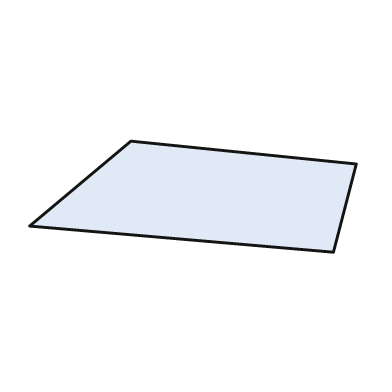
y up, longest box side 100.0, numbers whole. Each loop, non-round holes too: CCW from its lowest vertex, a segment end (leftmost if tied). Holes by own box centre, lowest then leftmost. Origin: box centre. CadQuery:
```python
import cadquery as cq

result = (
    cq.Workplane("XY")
    .moveTo(43.0, -17.0)
    .lineTo(50.0, 10.0)
    .lineTo(-19.0, 17.0)
    .lineTo(-50.0, -9.0)
    .close()
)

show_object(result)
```